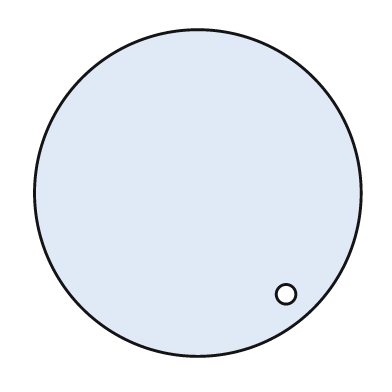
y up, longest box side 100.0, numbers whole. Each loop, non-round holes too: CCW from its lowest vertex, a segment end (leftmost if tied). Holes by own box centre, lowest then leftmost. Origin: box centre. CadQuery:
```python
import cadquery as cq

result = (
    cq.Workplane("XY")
    .moveTo(0.0, 0.0)
    .circle(50.0)
    .moveTo(27.0, -31.0)
    .circle(3.0)
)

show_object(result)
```